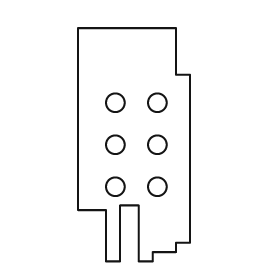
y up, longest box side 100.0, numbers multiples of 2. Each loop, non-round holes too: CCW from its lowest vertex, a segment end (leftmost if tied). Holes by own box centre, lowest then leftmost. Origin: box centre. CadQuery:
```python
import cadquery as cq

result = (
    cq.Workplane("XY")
    .moveTo(-12.0, -50.0)
    .lineTo(-6.0, -50.0)
    .lineTo(-6.0, -26.0)
    .lineTo(2.0, -26.0)
    .lineTo(2.0, -50.0)
    .lineTo(8.0, -50.0)
    .lineTo(8.0, -46.0)
    .lineTo(18.0, -46.0)
    .lineTo(18.0, -42.0)
    .lineTo(24.0, -42.0)
    .lineTo(24.0, 30.0)
    .lineTo(18.0, 30.0)
    .lineTo(18.0, 50.0)
    .lineTo(-24.0, 50.0)
    .lineTo(-24.0, -28.0)
    .lineTo(-12.0, -28.0)
    .close()
    .moveTo(-8.0, -18.0)
    .circle(4.0)
    .moveTo(10.0, -18.0)
    .circle(4.0)
    .moveTo(-8.0, 0.0)
    .circle(4.0)
    .moveTo(10.0, 0.0)
    .circle(4.0)
    .moveTo(-8.0, 18.0)
    .circle(4.0)
    .moveTo(10.0, 18.0)
    .circle(4.0)
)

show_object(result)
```